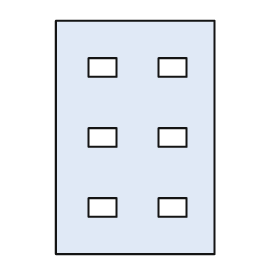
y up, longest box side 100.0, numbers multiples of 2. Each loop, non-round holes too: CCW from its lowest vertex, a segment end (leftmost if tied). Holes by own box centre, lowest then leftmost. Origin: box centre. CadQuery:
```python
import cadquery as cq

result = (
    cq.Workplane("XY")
    .moveTo(-34.0, -50.0)
    .lineTo(34.0, -50.0)
    .lineTo(34.0, 50.0)
    .lineTo(-34.0, 50.0)
    .close()
    .moveTo(-20.0, -34.0)
    .lineTo(-8.0, -34.0)
    .lineTo(-8.0, -26.0)
    .lineTo(-20.0, -26.0)
    .close()
    .moveTo(10.0, -34.0)
    .lineTo(22.0, -34.0)
    .lineTo(22.0, -26.0)
    .lineTo(10.0, -26.0)
    .close()
    .moveTo(-20.0, -4.0)
    .lineTo(-8.0, -4.0)
    .lineTo(-8.0, 4.0)
    .lineTo(-20.0, 4.0)
    .close()
    .moveTo(10.0, -4.0)
    .lineTo(22.0, -4.0)
    .lineTo(22.0, 4.0)
    .lineTo(10.0, 4.0)
    .close()
    .moveTo(-20.0, 26.0)
    .lineTo(-8.0, 26.0)
    .lineTo(-8.0, 34.0)
    .lineTo(-20.0, 34.0)
    .close()
    .moveTo(10.0, 26.0)
    .lineTo(22.0, 26.0)
    .lineTo(22.0, 34.0)
    .lineTo(10.0, 34.0)
    .close()
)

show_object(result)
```